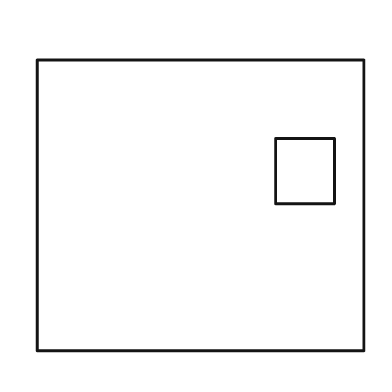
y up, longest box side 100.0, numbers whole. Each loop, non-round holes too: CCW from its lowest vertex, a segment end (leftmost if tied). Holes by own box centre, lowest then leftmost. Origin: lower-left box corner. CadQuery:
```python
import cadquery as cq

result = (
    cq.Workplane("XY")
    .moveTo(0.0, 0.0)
    .lineTo(100.0, 0.0)
    .lineTo(100.0, 89.0)
    .lineTo(0.0, 89.0)
    .close()
    .moveTo(73.0, 45.0)
    .lineTo(91.0, 45.0)
    .lineTo(91.0, 65.0)
    .lineTo(73.0, 65.0)
    .close()
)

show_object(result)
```